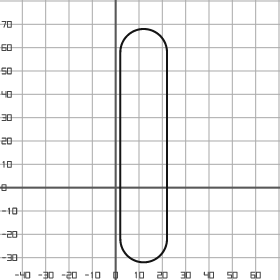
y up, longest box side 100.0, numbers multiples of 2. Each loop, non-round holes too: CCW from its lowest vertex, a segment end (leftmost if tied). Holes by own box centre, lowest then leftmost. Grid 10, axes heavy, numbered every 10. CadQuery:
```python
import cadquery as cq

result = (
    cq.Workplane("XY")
    .moveTo(2.0, -22.0)
    .threePointArc((12.0, -32.0), (22.0, -22.0))
    .lineTo(22.0, 58.0)
    .threePointArc((12.0, 68.0), (2.0, 58.0))
    .close()
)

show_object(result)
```